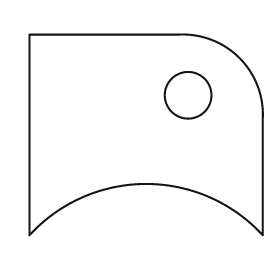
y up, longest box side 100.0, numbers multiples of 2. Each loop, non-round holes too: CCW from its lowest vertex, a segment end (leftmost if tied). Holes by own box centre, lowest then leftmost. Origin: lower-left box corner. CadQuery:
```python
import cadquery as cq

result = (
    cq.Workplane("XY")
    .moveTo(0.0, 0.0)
    .threePointArc((50.0, 22.0), (100.0, 0.0))
    .lineTo(100.0, 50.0)
    .threePointArc((90.0, 76.0), (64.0, 86.0))
    .lineTo(0.0, 86.0)
    .close()
    .moveTo(68.0, 60.0)
    .circle(10.0)
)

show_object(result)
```